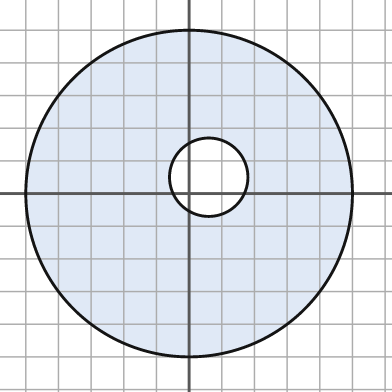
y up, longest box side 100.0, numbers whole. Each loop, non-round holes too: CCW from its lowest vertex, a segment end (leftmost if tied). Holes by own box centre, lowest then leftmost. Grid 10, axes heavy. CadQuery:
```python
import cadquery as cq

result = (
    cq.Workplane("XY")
    .moveTo(0.0, 0.0)
    .circle(50.0)
    .moveTo(6.0, 5.0)
    .circle(12.0)
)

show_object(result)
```